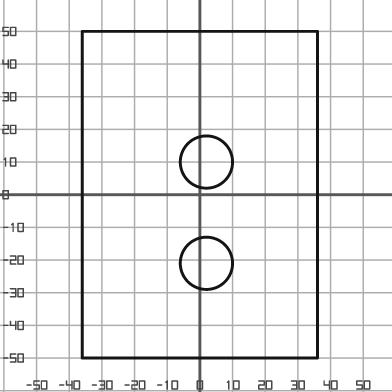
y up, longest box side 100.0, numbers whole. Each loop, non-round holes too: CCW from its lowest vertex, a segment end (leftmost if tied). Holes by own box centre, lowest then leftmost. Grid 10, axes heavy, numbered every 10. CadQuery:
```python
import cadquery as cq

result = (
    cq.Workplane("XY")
    .moveTo(-36.0, -50.0)
    .lineTo(36.0, -50.0)
    .lineTo(36.0, 50.0)
    .lineTo(-36.0, 50.0)
    .close()
    .moveTo(2.0, -21.0)
    .circle(8.0)
    .moveTo(2.0, 10.0)
    .circle(8.0)
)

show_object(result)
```